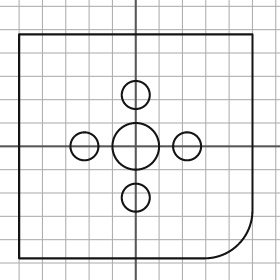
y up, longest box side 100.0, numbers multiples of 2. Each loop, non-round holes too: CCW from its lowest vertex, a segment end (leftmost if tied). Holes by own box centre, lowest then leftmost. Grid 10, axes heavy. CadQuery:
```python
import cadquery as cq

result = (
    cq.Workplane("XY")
    .moveTo(-50.0, -48.0)
    .lineTo(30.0, -48.0)
    .threePointArc((44.0, -42.0), (50.0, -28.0))
    .lineTo(50.0, 48.0)
    .lineTo(-50.0, 48.0)
    .close()
    .moveTo(0.0, -22.0)
    .circle(6.0)
    .moveTo(-22.0, 0.0)
    .circle(6.0)
    .moveTo(0.0, 0.0)
    .circle(10.0)
    .moveTo(22.0, 0.0)
    .circle(6.0)
    .moveTo(0.0, 22.0)
    .circle(6.0)
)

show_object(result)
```